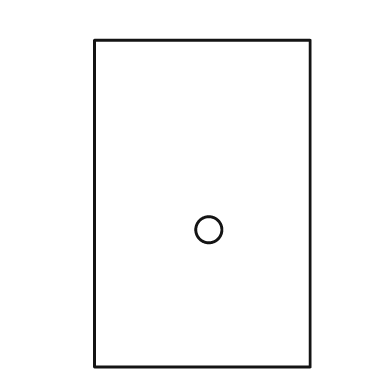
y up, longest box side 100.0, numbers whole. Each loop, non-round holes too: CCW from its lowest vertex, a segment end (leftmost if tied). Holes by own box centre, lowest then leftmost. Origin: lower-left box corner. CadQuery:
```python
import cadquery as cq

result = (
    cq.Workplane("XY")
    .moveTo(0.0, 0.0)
    .lineTo(66.0, 0.0)
    .lineTo(66.0, 100.0)
    .lineTo(0.0, 100.0)
    .close()
    .moveTo(35.0, 42.0)
    .circle(4.0)
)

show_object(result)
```